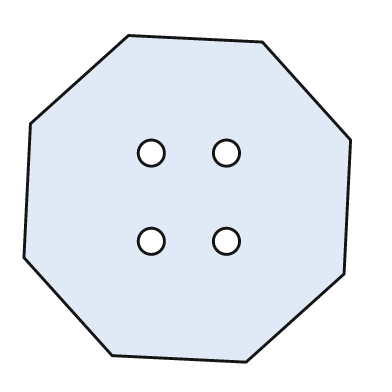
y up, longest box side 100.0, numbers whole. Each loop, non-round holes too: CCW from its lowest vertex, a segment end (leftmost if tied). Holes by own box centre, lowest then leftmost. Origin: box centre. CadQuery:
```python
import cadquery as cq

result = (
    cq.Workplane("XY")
    .moveTo(18.0, -50.0)
    .lineTo(48.0, -23.0)
    .lineTo(50.0, 18.0)
    .lineTo(23.0, 48.0)
    .lineTo(-18.0, 50.0)
    .lineTo(-48.0, 23.0)
    .lineTo(-50.0, -18.0)
    .lineTo(-23.0, -48.0)
    .close()
    .moveTo(-11.0, -13.0)
    .circle(4.0)
    .moveTo(12.0, -13.0)
    .circle(4.0)
    .moveTo(-11.0, 14.0)
    .circle(4.0)
    .moveTo(12.0, 14.0)
    .circle(4.0)
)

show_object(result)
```